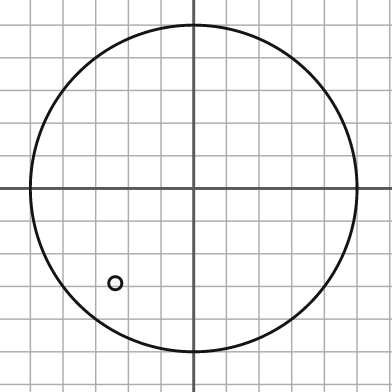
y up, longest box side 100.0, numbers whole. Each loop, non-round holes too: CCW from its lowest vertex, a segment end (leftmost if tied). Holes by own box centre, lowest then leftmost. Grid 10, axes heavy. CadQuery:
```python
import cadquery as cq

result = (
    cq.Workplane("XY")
    .moveTo(0.0, 0.0)
    .circle(50.0)
    .moveTo(-24.0, -29.0)
    .circle(2.0)
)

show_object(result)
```